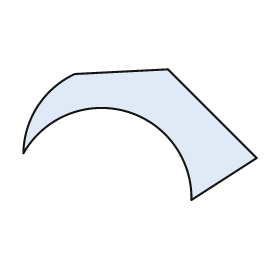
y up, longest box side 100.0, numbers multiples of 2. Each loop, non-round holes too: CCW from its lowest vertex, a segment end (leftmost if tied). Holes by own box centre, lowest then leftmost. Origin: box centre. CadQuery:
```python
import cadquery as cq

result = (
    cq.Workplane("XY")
    .moveTo(22.0, -28.0)
    .lineTo(50.0, -10.0)
    .lineTo(12.0, 28.0)
    .lineTo(-28.0, 26.0)
    .threePointArc((-44.0, 12.0), (-50.0, -8.0))
    .threePointArc((-6.0, 10.0), (22.0, -28.0))
    .close()
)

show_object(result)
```